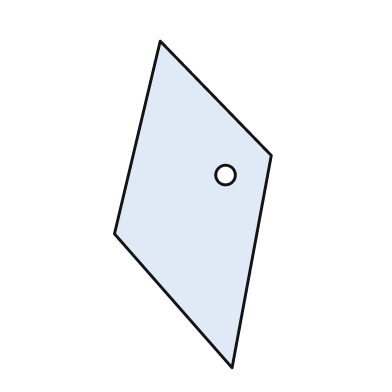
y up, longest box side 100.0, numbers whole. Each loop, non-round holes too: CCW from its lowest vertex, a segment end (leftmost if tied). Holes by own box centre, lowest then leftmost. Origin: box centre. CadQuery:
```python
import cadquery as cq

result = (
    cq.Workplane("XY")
    .moveTo(12.0, -50.0)
    .lineTo(24.0, 15.0)
    .lineTo(-10.0, 50.0)
    .lineTo(-24.0, -9.0)
    .close()
    .moveTo(10.0, 9.0)
    .circle(3.0)
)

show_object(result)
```